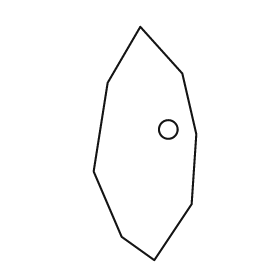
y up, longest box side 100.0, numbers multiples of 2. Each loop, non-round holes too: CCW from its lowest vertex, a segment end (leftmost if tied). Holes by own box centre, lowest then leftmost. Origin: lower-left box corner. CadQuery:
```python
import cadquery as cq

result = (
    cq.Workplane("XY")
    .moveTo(26.0, 0.0)
    .lineTo(42.0, 24.0)
    .lineTo(44.0, 54.0)
    .lineTo(38.0, 80.0)
    .lineTo(20.0, 100.0)
    .lineTo(6.0, 76.0)
    .lineTo(0.0, 38.0)
    .lineTo(12.0, 10.0)
    .close()
    .moveTo(32.0, 56.0)
    .circle(4.0)
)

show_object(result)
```